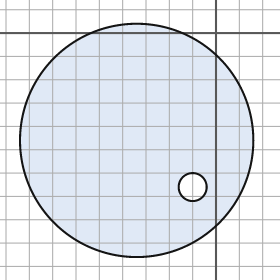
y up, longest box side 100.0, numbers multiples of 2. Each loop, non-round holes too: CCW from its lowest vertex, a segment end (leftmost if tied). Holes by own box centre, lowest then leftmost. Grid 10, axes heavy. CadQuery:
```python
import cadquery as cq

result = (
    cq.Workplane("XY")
    .moveTo(-34.0, -46.0)
    .circle(50.0)
    .moveTo(-10.0, -66.0)
    .circle(6.0)
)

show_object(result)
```